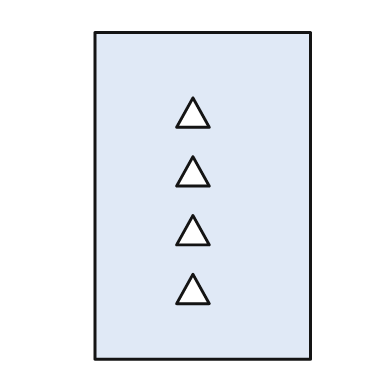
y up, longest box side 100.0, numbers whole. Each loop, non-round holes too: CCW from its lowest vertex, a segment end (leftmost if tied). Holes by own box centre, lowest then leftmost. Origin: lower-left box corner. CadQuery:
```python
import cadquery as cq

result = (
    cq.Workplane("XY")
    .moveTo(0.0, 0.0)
    .lineTo(66.0, 0.0)
    .lineTo(66.0, 100.0)
    .lineTo(0.0, 100.0)
    .close()
    .moveTo(25.0, 17.0)
    .lineTo(35.0, 17.0)
    .lineTo(30.0, 26.0)
    .close()
    .moveTo(25.0, 35.0)
    .lineTo(35.0, 35.0)
    .lineTo(30.0, 44.0)
    .close()
    .moveTo(25.0, 53.0)
    .lineTo(35.0, 53.0)
    .lineTo(30.0, 62.0)
    .close()
    .moveTo(25.0, 71.0)
    .lineTo(35.0, 71.0)
    .lineTo(30.0, 80.0)
    .close()
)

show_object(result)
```